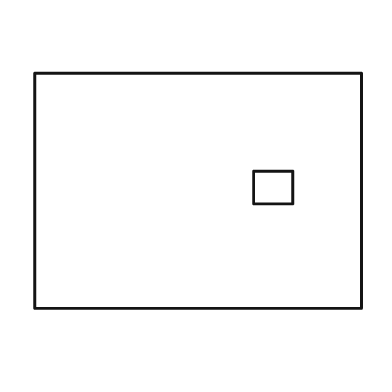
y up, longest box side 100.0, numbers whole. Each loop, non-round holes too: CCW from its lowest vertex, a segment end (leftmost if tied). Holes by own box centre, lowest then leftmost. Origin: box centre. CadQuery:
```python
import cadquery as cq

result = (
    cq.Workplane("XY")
    .moveTo(-50.0, -36.0)
    .lineTo(50.0, -36.0)
    .lineTo(50.0, 36.0)
    .lineTo(-50.0, 36.0)
    .close()
    .moveTo(17.0, -4.0)
    .lineTo(29.0, -4.0)
    .lineTo(29.0, 6.0)
    .lineTo(17.0, 6.0)
    .close()
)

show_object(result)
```